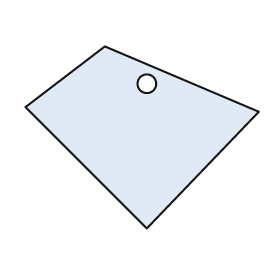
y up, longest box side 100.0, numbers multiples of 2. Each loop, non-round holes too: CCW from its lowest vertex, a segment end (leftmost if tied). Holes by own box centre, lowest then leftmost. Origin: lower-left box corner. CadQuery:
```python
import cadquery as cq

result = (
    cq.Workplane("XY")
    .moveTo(52.0, 0.0)
    .lineTo(100.0, 50.0)
    .lineTo(34.0, 78.0)
    .lineTo(0.0, 52.0)
    .close()
    .moveTo(52.0, 62.0)
    .circle(4.0)
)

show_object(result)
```